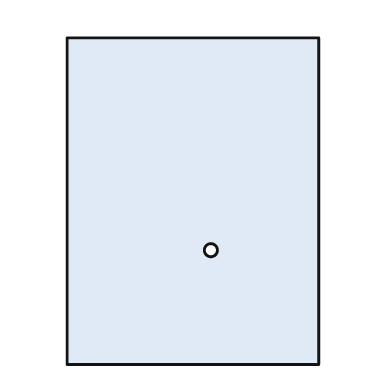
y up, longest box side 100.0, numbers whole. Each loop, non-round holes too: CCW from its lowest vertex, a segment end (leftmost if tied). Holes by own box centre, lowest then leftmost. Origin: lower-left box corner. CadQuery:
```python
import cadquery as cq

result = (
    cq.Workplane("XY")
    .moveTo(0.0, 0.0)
    .lineTo(77.0, 0.0)
    .lineTo(77.0, 100.0)
    .lineTo(0.0, 100.0)
    .close()
    .moveTo(44.0, 35.0)
    .circle(2.0)
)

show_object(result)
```